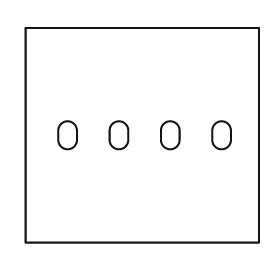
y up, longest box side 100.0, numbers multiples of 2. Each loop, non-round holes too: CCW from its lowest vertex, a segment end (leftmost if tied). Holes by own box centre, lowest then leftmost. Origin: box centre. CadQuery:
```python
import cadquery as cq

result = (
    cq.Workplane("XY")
    .moveTo(-50.0, -46.0)
    .lineTo(50.0, -46.0)
    .lineTo(50.0, 46.0)
    .lineTo(-50.0, 46.0)
    .close()
    .moveTo(-36.0, -2.0)
    .threePointArc((-32.0, -6.0), (-28.0, -2.0))
    .lineTo(-28.0, 2.0)
    .threePointArc((-32.0, 6.0), (-36.0, 2.0))
    .close()
    .moveTo(-14.0, -2.0)
    .threePointArc((-10.0, -6.0), (-6.0, -2.0))
    .lineTo(-6.0, 2.0)
    .threePointArc((-10.0, 6.0), (-14.0, 2.0))
    .close()
    .moveTo(8.0, -2.0)
    .threePointArc((12.0, -6.0), (16.0, -2.0))
    .lineTo(16.0, 2.0)
    .threePointArc((12.0, 6.0), (8.0, 2.0))
    .close()
    .moveTo(30.0, -2.0)
    .threePointArc((34.0, -6.0), (38.0, -2.0))
    .lineTo(38.0, 2.0)
    .threePointArc((34.0, 6.0), (30.0, 2.0))
    .close()
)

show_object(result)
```